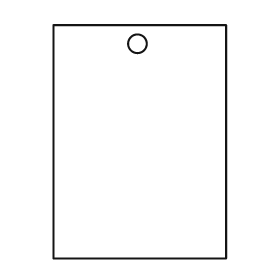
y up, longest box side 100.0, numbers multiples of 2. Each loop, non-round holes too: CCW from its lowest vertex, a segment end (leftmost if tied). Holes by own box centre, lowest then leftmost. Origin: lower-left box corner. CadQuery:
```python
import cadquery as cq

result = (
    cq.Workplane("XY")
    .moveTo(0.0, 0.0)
    .lineTo(74.0, 0.0)
    .lineTo(74.0, 100.0)
    .lineTo(0.0, 100.0)
    .close()
    .moveTo(36.0, 92.0)
    .circle(4.0)
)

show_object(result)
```